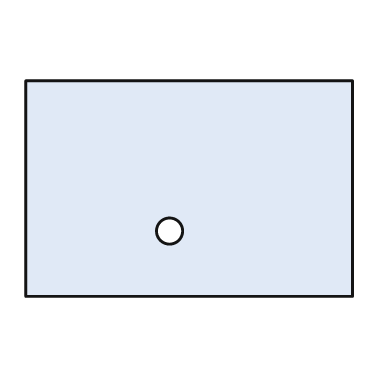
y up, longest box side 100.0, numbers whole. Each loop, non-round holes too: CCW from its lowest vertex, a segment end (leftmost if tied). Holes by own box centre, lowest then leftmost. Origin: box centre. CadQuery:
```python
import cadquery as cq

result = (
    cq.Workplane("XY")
    .moveTo(-50.0, -33.0)
    .lineTo(50.0, -33.0)
    .lineTo(50.0, 33.0)
    .lineTo(-50.0, 33.0)
    .close()
    .moveTo(-6.0, -13.0)
    .circle(4.0)
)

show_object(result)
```